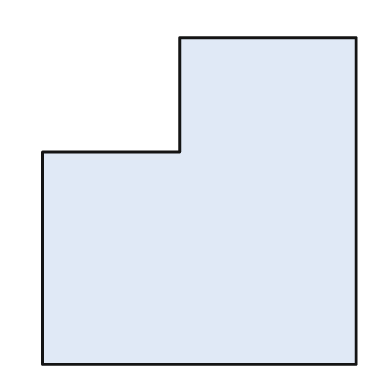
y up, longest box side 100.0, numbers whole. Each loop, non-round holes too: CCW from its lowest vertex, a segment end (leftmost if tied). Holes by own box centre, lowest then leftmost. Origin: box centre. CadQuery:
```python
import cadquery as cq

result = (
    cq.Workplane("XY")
    .moveTo(-48.0, -50.0)
    .lineTo(48.0, -50.0)
    .lineTo(48.0, 50.0)
    .lineTo(-6.0, 50.0)
    .lineTo(-6.0, 15.0)
    .lineTo(-48.0, 15.0)
    .close()
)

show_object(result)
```